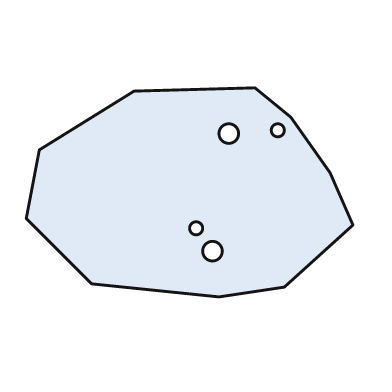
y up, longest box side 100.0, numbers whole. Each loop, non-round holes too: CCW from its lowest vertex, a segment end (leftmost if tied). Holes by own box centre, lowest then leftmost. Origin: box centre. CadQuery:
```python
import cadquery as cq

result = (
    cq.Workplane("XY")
    .moveTo(9.0, -32.0)
    .lineTo(29.0, -29.0)
    .lineTo(50.0, -10.0)
    .lineTo(43.0, 6.0)
    .lineTo(31.0, 23.0)
    .lineTo(20.0, 32.0)
    .lineTo(-17.0, 31.0)
    .lineTo(-46.0, 13.0)
    .lineTo(-50.0, -8.0)
    .lineTo(-30.0, -28.0)
    .close()
    .moveTo(7.0, -18.0)
    .circle(3.0)
    .moveTo(2.0, -11.0)
    .circle(2.0)
    .moveTo(12.0, 18.0)
    .circle(3.0)
    .moveTo(27.0, 19.0)
    .circle(2.0)
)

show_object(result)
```